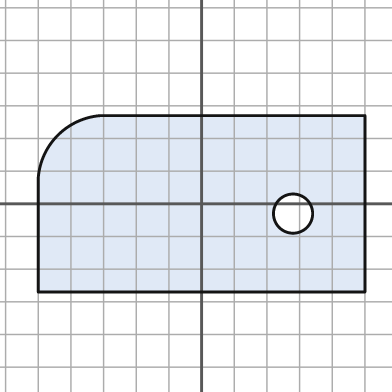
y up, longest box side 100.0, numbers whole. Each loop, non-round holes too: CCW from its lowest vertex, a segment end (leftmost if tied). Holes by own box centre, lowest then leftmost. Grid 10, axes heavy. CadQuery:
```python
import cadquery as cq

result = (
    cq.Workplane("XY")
    .moveTo(-50.0, -27.0)
    .lineTo(50.0, -27.0)
    .lineTo(50.0, 27.0)
    .lineTo(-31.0, 27.0)
    .threePointArc((-44.0, 21.0), (-50.0, 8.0))
    .close()
    .moveTo(28.0, -3.0)
    .circle(6.0)
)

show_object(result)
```